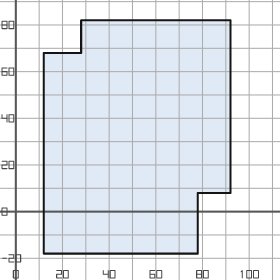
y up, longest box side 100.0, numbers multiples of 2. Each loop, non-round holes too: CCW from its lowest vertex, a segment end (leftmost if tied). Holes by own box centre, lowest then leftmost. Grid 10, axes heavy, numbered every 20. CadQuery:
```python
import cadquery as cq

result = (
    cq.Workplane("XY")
    .moveTo(12.0, -18.0)
    .lineTo(78.0, -18.0)
    .lineTo(78.0, 8.0)
    .lineTo(92.0, 8.0)
    .lineTo(92.0, 82.0)
    .lineTo(28.0, 82.0)
    .lineTo(28.0, 68.0)
    .lineTo(12.0, 68.0)
    .close()
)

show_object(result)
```